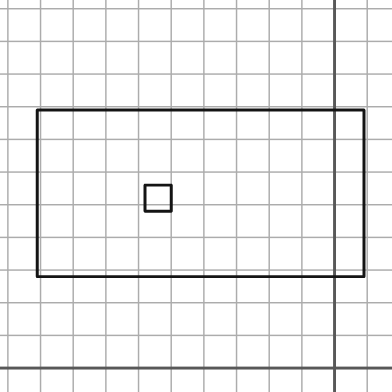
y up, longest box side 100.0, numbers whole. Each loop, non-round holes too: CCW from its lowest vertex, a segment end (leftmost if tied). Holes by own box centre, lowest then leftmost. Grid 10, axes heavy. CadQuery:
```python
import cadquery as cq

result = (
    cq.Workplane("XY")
    .moveTo(-91.0, 28.0)
    .lineTo(9.0, 28.0)
    .lineTo(9.0, 79.0)
    .lineTo(-91.0, 79.0)
    .close()
    .moveTo(-58.0, 48.0)
    .lineTo(-50.0, 48.0)
    .lineTo(-50.0, 56.0)
    .lineTo(-58.0, 56.0)
    .close()
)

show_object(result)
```